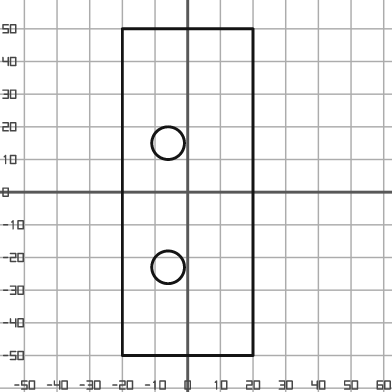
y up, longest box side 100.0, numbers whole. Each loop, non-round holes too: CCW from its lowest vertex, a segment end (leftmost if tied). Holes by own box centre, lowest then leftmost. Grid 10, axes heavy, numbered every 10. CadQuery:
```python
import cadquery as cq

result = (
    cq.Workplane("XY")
    .moveTo(-20.0, -50.0)
    .lineTo(20.0, -50.0)
    .lineTo(20.0, 50.0)
    .lineTo(-20.0, 50.0)
    .close()
    .moveTo(-6.0, -23.0)
    .circle(5.0)
    .moveTo(-6.0, 15.0)
    .circle(5.0)
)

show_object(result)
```